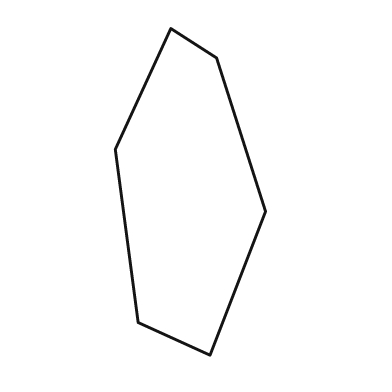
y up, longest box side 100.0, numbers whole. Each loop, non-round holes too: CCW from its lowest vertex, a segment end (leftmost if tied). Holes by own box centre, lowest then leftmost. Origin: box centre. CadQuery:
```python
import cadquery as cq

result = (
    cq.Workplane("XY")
    .moveTo(6.0, -50.0)
    .lineTo(23.0, -6.0)
    .lineTo(8.0, 41.0)
    .lineTo(-6.0, 50.0)
    .lineTo(-23.0, 13.0)
    .lineTo(-16.0, -40.0)
    .close()
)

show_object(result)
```